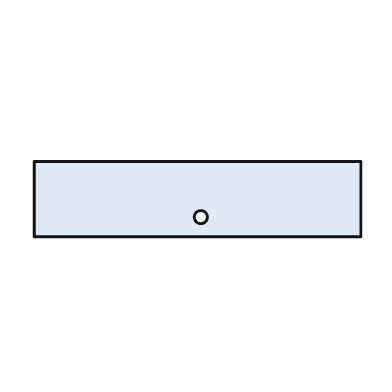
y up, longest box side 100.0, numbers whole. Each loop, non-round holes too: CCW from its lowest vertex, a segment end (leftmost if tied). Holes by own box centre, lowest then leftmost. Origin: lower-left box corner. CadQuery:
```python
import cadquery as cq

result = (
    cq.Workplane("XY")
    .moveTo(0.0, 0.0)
    .lineTo(100.0, 0.0)
    .lineTo(100.0, 23.0)
    .lineTo(0.0, 23.0)
    .close()
    .moveTo(51.0, 6.0)
    .circle(2.0)
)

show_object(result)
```